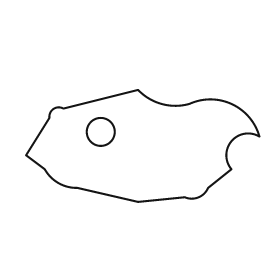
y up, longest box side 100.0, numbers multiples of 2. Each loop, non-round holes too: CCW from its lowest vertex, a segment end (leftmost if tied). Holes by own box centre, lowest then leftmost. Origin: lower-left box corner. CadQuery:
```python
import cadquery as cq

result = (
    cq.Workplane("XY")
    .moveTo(48.0, 0.0)
    .lineTo(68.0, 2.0)
    .threePointArc((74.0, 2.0), (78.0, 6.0))
    .lineTo(88.0, 14.0)
    .threePointArc((88.0, 26.0), (100.0, 28.0))
    .threePointArc((88.0, 42.0), (70.0, 42.0))
    .threePointArc((58.0, 42.0), (48.0, 48.0))
    .lineTo(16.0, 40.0)
    .threePointArc((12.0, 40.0), (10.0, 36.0))
    .lineTo(0.0, 20.0)
    .lineTo(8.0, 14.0)
    .threePointArc((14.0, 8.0), (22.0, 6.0))
    .close()
    .moveTo(32.0, 30.0)
    .circle(6.0)
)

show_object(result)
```